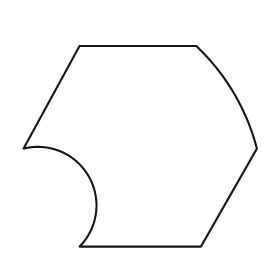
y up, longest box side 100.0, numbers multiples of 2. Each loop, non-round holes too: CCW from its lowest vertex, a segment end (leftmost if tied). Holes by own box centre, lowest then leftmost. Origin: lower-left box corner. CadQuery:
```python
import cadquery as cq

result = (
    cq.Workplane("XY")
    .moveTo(24.0, 0.0)
    .lineTo(76.0, 0.0)
    .lineTo(100.0, 42.0)
    .threePointArc((90.0, 66.0), (74.0, 86.0))
    .lineTo(24.0, 86.0)
    .lineTo(0.0, 42.0)
    .threePointArc((28.0, 30.0), (24.0, 0.0))
    .close()
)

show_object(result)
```